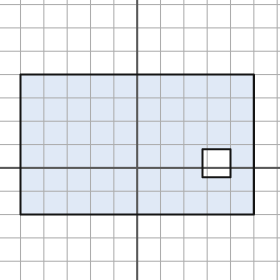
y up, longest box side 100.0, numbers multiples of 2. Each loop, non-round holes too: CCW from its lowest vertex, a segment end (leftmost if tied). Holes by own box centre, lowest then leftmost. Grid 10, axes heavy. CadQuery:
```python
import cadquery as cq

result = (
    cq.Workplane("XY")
    .moveTo(-50.0, -20.0)
    .lineTo(50.0, -20.0)
    .lineTo(50.0, 40.0)
    .lineTo(-50.0, 40.0)
    .close()
    .moveTo(28.0, -4.0)
    .lineTo(40.0, -4.0)
    .lineTo(40.0, 8.0)
    .lineTo(28.0, 8.0)
    .close()
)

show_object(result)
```